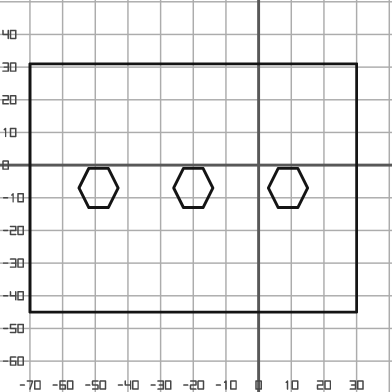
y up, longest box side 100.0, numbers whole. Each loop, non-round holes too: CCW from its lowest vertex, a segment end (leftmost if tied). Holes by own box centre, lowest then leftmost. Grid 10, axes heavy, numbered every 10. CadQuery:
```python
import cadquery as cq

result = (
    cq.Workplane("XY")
    .moveTo(-70.0, -45.0)
    .lineTo(30.0, -45.0)
    .lineTo(30.0, 31.0)
    .lineTo(-70.0, 31.0)
    .close()
    .moveTo(-52.0, -13.0)
    .lineTo(-46.0, -13.0)
    .lineTo(-43.0, -7.0)
    .lineTo(-46.0, -1.0)
    .lineTo(-52.0, -1.0)
    .lineTo(-55.0, -7.0)
    .close()
    .moveTo(-23.0, -13.0)
    .lineTo(-17.0, -13.0)
    .lineTo(-14.0, -7.0)
    .lineTo(-17.0, -1.0)
    .lineTo(-23.0, -1.0)
    .lineTo(-26.0, -7.0)
    .close()
    .moveTo(6.0, -13.0)
    .lineTo(12.0, -13.0)
    .lineTo(15.0, -7.0)
    .lineTo(12.0, -1.0)
    .lineTo(6.0, -1.0)
    .lineTo(3.0, -7.0)
    .close()
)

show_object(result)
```